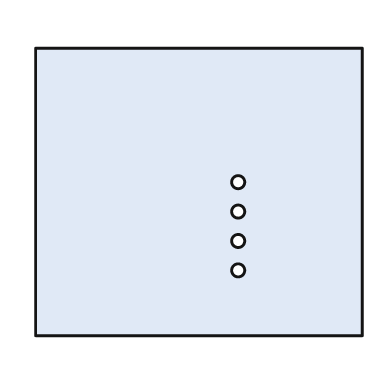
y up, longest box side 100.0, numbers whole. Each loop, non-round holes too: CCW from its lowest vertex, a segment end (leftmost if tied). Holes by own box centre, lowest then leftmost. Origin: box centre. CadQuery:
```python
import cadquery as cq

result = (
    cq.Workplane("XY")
    .moveTo(-50.0, -44.0)
    .lineTo(50.0, -44.0)
    .lineTo(50.0, 44.0)
    .lineTo(-50.0, 44.0)
    .close()
    .moveTo(12.0, -24.0)
    .circle(2.0)
    .moveTo(12.0, -15.0)
    .circle(2.0)
    .moveTo(12.0, -6.0)
    .circle(2.0)
    .moveTo(12.0, 3.0)
    .circle(2.0)
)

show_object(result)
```